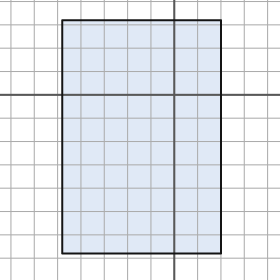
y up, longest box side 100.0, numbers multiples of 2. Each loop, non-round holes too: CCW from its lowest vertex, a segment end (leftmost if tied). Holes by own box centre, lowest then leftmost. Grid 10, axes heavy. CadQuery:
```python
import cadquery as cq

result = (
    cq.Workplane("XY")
    .moveTo(-48.0, -68.0)
    .lineTo(20.0, -68.0)
    .lineTo(20.0, 32.0)
    .lineTo(-48.0, 32.0)
    .close()
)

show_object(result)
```